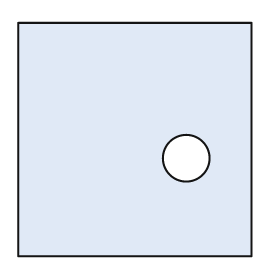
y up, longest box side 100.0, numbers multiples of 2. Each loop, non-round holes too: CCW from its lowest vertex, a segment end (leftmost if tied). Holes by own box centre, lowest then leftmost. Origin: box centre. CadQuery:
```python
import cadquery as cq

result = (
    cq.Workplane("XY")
    .moveTo(-50.0, -50.0)
    .lineTo(50.0, -50.0)
    .lineTo(50.0, 50.0)
    .lineTo(-50.0, 50.0)
    .close()
    .moveTo(22.0, -8.0)
    .circle(10.0)
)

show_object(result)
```